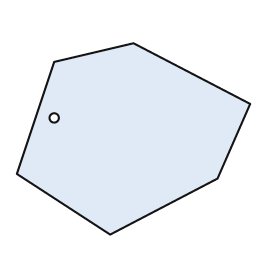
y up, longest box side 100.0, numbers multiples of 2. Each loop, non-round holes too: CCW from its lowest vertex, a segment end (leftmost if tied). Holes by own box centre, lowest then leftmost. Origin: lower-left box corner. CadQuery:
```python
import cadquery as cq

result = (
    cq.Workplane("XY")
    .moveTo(40.0, 0.0)
    .lineTo(86.0, 24.0)
    .lineTo(100.0, 56.0)
    .lineTo(50.0, 82.0)
    .lineTo(16.0, 74.0)
    .lineTo(0.0, 26.0)
    .close()
    .moveTo(16.0, 50.0)
    .circle(2.0)
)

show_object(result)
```